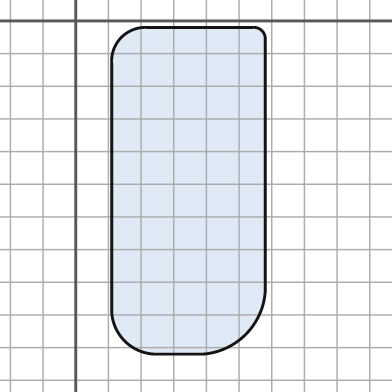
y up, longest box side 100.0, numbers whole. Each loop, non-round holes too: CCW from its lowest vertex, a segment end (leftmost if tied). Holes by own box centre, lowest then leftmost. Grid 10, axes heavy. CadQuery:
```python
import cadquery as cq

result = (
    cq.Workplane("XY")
    .moveTo(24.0, -102.0)
    .lineTo(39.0, -102.0)
    .threePointArc((52.0, -96.0), (58.0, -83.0))
    .lineTo(58.0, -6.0)
    .threePointArc((57.0, -3.0), (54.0, -2.0))
    .lineTo(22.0, -2.0)
    .threePointArc((14.0, -5.0), (11.0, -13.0))
    .lineTo(11.0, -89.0)
    .threePointArc((15.0, -98.0), (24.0, -102.0))
    .close()
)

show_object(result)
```